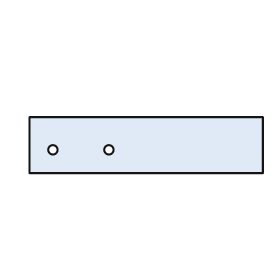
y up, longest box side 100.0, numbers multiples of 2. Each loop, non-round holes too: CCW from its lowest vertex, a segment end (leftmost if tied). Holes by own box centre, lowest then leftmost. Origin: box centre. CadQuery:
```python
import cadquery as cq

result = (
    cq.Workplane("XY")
    .moveTo(-50.0, -12.0)
    .lineTo(50.0, -12.0)
    .lineTo(50.0, 12.0)
    .lineTo(-50.0, 12.0)
    .close()
    .moveTo(-40.0, -2.0)
    .circle(2.0)
    .moveTo(-16.0, -2.0)
    .circle(2.0)
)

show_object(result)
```